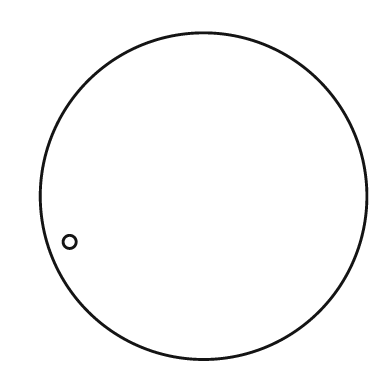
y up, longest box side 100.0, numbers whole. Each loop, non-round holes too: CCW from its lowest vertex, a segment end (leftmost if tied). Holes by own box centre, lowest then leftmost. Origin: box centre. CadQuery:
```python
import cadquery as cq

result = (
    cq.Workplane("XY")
    .moveTo(0.0, 0.0)
    .circle(50.0)
    .moveTo(-41.0, -14.0)
    .circle(2.0)
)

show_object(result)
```